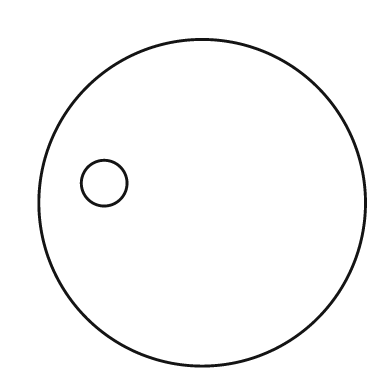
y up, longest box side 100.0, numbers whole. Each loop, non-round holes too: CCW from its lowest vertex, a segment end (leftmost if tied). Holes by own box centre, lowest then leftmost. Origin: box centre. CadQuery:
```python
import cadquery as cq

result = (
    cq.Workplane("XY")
    .moveTo(0.0, 0.0)
    .circle(50.0)
    .moveTo(-30.0, 6.0)
    .circle(7.0)
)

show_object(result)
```